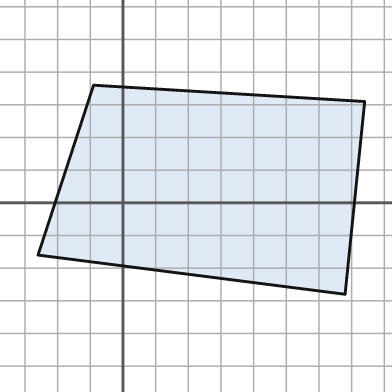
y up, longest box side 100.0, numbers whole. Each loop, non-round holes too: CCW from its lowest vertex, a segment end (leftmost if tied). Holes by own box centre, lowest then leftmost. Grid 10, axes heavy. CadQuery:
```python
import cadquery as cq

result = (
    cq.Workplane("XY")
    .moveTo(68.0, -28.0)
    .lineTo(74.0, 31.0)
    .lineTo(-9.0, 36.0)
    .lineTo(-26.0, -16.0)
    .close()
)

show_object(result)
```